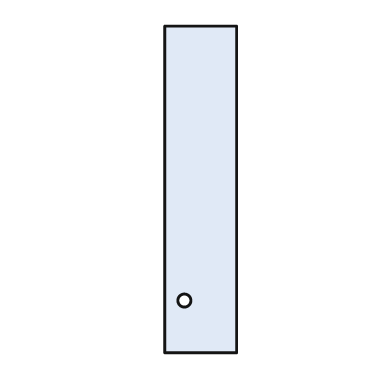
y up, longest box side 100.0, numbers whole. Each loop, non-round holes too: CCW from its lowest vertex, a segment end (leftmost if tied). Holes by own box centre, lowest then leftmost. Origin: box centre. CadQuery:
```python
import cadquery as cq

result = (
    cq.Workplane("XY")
    .moveTo(-11.0, -50.0)
    .lineTo(11.0, -50.0)
    .lineTo(11.0, 50.0)
    .lineTo(-11.0, 50.0)
    .close()
    .moveTo(-5.0, -34.0)
    .circle(2.0)
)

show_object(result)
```